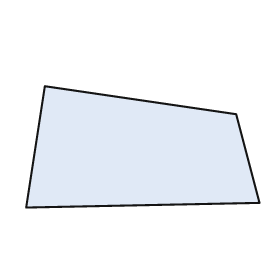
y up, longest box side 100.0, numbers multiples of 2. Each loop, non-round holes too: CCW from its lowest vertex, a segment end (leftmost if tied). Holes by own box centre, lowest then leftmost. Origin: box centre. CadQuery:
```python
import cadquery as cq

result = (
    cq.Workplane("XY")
    .moveTo(-50.0, -26.0)
    .lineTo(50.0, -24.0)
    .lineTo(40.0, 14.0)
    .lineTo(-42.0, 26.0)
    .close()
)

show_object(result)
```